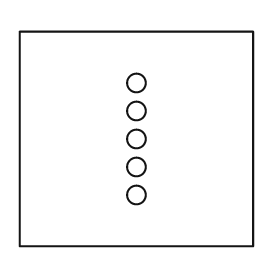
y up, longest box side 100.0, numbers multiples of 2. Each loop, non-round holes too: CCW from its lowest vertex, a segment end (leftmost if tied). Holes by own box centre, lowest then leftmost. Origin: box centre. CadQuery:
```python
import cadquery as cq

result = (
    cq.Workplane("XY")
    .moveTo(-50.0, -46.0)
    .lineTo(50.0, -46.0)
    .lineTo(50.0, 46.0)
    .lineTo(-50.0, 46.0)
    .close()
    .moveTo(0.0, -24.0)
    .circle(4.0)
    .moveTo(0.0, -12.0)
    .circle(4.0)
    .moveTo(0.0, 0.0)
    .circle(4.0)
    .moveTo(0.0, 12.0)
    .circle(4.0)
    .moveTo(0.0, 24.0)
    .circle(4.0)
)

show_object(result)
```